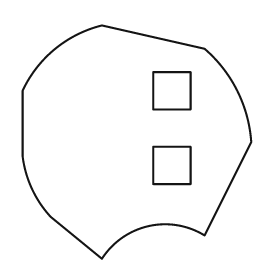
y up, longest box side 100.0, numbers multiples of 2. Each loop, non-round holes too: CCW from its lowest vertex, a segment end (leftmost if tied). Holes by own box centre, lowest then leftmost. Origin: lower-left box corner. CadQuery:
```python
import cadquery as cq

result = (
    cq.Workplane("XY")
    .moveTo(34.0, 0.0)
    .threePointArc((54.0, 14.0), (78.0, 10.0))
    .lineTo(98.0, 50.0)
    .threePointArc((92.0, 72.0), (78.0, 90.0))
    .lineTo(34.0, 100.0)
    .threePointArc((14.0, 90.0), (0.0, 72.0))
    .lineTo(0.0, 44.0)
    .threePointArc((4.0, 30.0), (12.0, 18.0))
    .close()
    .moveTo(56.0, 32.0)
    .lineTo(72.0, 32.0)
    .lineTo(72.0, 48.0)
    .lineTo(56.0, 48.0)
    .close()
    .moveTo(56.0, 64.0)
    .lineTo(72.0, 64.0)
    .lineTo(72.0, 80.0)
    .lineTo(56.0, 80.0)
    .close()
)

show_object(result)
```